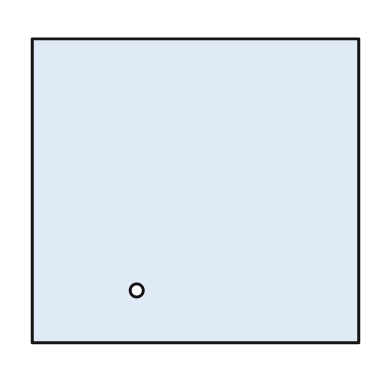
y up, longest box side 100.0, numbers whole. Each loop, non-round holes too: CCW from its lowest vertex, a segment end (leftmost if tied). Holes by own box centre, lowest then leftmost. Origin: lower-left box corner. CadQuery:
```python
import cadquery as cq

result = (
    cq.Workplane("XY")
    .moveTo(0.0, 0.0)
    .lineTo(100.0, 0.0)
    .lineTo(100.0, 93.0)
    .lineTo(0.0, 93.0)
    .close()
    .moveTo(32.0, 16.0)
    .circle(2.0)
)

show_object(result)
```